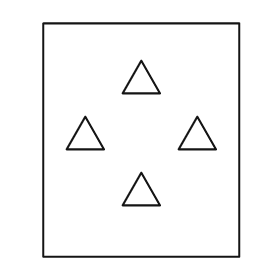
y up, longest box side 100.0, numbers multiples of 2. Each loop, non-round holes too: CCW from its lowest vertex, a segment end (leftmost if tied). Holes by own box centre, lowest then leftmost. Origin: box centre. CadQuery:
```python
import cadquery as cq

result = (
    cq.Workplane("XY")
    .moveTo(-42.0, -50.0)
    .lineTo(42.0, -50.0)
    .lineTo(42.0, 50.0)
    .lineTo(-42.0, 50.0)
    .close()
    .moveTo(-8.0, -28.0)
    .lineTo(8.0, -28.0)
    .lineTo(0.0, -14.0)
    .close()
    .moveTo(-32.0, -4.0)
    .lineTo(-16.0, -4.0)
    .lineTo(-24.0, 10.0)
    .close()
    .moveTo(16.0, -4.0)
    .lineTo(32.0, -4.0)
    .lineTo(24.0, 10.0)
    .close()
    .moveTo(-8.0, 20.0)
    .lineTo(8.0, 20.0)
    .lineTo(0.0, 34.0)
    .close()
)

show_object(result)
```